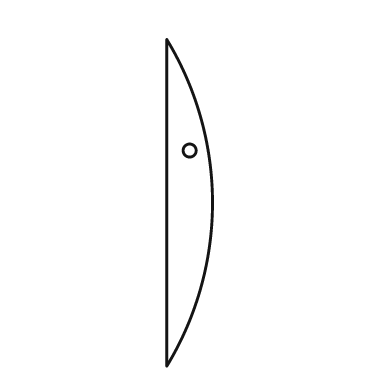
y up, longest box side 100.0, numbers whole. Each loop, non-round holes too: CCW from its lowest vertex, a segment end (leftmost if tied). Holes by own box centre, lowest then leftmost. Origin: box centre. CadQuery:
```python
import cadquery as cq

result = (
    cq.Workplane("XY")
    .moveTo(-7.0, -50.0)
    .threePointArc((7.0, 0.0), (-7.0, 50.0))
    .close()
    .moveTo(0.0, 16.0)
    .circle(2.0)
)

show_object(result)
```